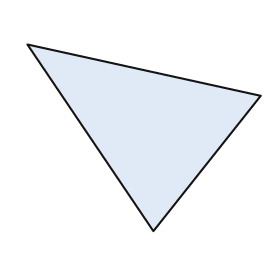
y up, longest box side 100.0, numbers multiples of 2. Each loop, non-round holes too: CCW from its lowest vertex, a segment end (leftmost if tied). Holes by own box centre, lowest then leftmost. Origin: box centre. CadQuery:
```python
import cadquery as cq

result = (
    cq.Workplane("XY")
    .moveTo(4.0, -40.0)
    .lineTo(50.0, 18.0)
    .lineTo(-50.0, 40.0)
    .close()
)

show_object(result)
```